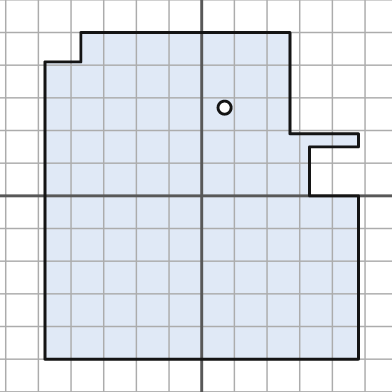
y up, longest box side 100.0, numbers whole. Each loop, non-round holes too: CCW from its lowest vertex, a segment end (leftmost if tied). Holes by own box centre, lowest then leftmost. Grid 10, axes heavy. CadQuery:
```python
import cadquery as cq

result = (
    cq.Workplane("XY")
    .moveTo(-48.0, -50.0)
    .lineTo(48.0, -50.0)
    .lineTo(48.0, 0.0)
    .lineTo(33.0, 0.0)
    .lineTo(33.0, 15.0)
    .lineTo(48.0, 15.0)
    .lineTo(48.0, 19.0)
    .lineTo(27.0, 19.0)
    .lineTo(27.0, 50.0)
    .lineTo(-37.0, 50.0)
    .lineTo(-37.0, 41.0)
    .lineTo(-48.0, 41.0)
    .close()
    .moveTo(7.0, 27.0)
    .circle(2.0)
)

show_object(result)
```